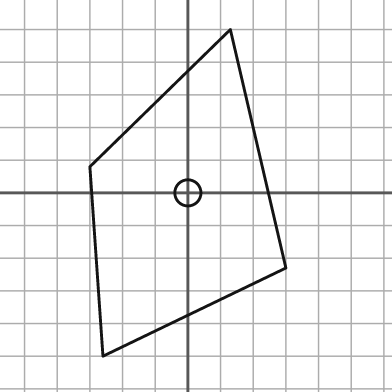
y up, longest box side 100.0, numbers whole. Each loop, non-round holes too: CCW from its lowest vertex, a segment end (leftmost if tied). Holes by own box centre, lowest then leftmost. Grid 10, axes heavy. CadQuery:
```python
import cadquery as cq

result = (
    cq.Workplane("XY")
    .moveTo(-26.0, -50.0)
    .lineTo(30.0, -23.0)
    .lineTo(13.0, 50.0)
    .lineTo(-30.0, 8.0)
    .close()
    .moveTo(0.0, 0.0)
    .circle(4.0)
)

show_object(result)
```